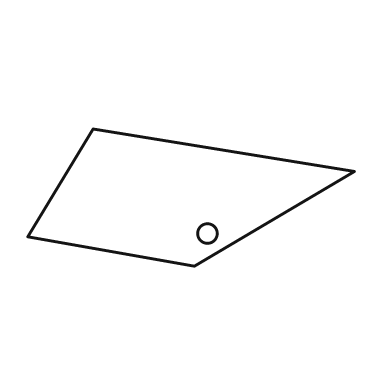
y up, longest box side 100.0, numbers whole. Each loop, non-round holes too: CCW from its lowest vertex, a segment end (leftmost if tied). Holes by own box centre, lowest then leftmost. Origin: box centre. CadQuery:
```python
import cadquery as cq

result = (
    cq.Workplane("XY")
    .moveTo(1.0, -21.0)
    .lineTo(50.0, 8.0)
    .lineTo(-30.0, 21.0)
    .lineTo(-50.0, -12.0)
    .close()
    .moveTo(5.0, -11.0)
    .circle(3.0)
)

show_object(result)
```